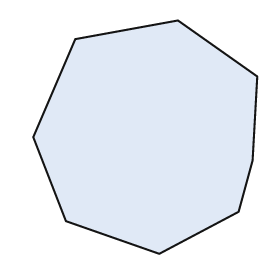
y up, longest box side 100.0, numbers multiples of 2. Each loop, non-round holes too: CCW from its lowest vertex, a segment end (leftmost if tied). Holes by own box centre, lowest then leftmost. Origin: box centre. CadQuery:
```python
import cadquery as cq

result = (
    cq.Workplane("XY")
    .moveTo(6.0, -50.0)
    .lineTo(40.0, -32.0)
    .lineTo(46.0, -10.0)
    .lineTo(48.0, 26.0)
    .lineTo(14.0, 50.0)
    .lineTo(-30.0, 42.0)
    .lineTo(-48.0, 0.0)
    .lineTo(-34.0, -36.0)
    .close()
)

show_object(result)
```